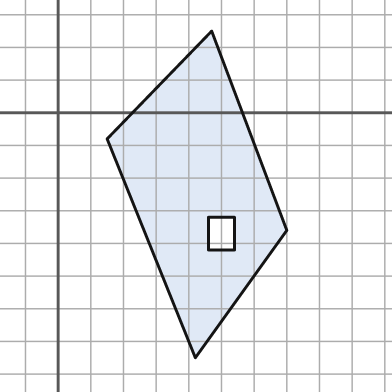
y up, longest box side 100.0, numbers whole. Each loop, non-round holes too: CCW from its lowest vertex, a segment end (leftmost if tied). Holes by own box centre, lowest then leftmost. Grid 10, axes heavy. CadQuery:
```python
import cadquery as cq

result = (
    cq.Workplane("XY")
    .moveTo(42.0, -75.0)
    .lineTo(70.0, -36.0)
    .lineTo(47.0, 25.0)
    .lineTo(15.0, -8.0)
    .close()
    .moveTo(46.0, -42.0)
    .lineTo(54.0, -42.0)
    .lineTo(54.0, -32.0)
    .lineTo(46.0, -32.0)
    .close()
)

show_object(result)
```